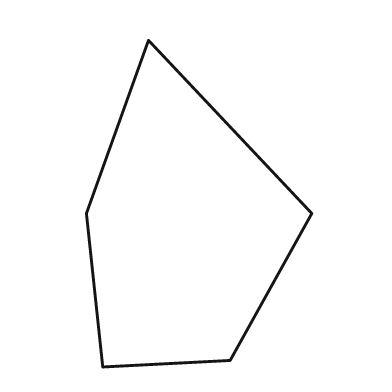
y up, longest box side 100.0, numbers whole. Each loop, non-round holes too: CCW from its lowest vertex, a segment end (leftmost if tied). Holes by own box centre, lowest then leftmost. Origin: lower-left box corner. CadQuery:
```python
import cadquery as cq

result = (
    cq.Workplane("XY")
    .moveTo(5.0, 0.0)
    .lineTo(44.0, 2.0)
    .lineTo(69.0, 47.0)
    .lineTo(19.0, 100.0)
    .lineTo(0.0, 47.0)
    .close()
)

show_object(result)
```